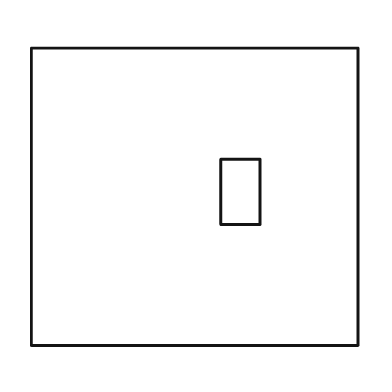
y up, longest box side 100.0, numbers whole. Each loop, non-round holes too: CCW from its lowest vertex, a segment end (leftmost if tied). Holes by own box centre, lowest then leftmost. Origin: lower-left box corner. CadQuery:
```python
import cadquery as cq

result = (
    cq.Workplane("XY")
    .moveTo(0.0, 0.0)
    .lineTo(100.0, 0.0)
    .lineTo(100.0, 91.0)
    .lineTo(0.0, 91.0)
    .close()
    .moveTo(58.0, 37.0)
    .lineTo(70.0, 37.0)
    .lineTo(70.0, 57.0)
    .lineTo(58.0, 57.0)
    .close()
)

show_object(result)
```